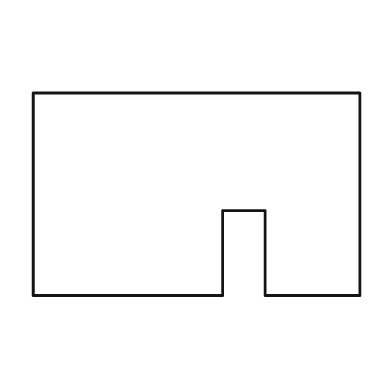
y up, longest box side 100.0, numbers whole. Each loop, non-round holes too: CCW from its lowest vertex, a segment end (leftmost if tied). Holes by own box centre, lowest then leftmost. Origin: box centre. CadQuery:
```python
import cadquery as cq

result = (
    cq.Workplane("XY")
    .moveTo(-50.0, -31.0)
    .lineTo(8.0, -31.0)
    .lineTo(8.0, -5.0)
    .lineTo(21.0, -5.0)
    .lineTo(21.0, -31.0)
    .lineTo(50.0, -31.0)
    .lineTo(50.0, 31.0)
    .lineTo(-50.0, 31.0)
    .close()
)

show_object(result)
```